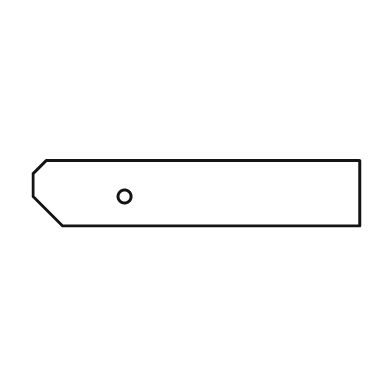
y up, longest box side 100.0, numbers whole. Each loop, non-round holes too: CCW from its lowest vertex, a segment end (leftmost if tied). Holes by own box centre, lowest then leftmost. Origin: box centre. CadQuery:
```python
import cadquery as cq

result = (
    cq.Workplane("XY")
    .moveTo(-41.0, -10.0)
    .lineTo(50.0, -10.0)
    .lineTo(50.0, 10.0)
    .lineTo(-46.0, 10.0)
    .lineTo(-50.0, 6.0)
    .lineTo(-50.0, -1.0)
    .close()
    .moveTo(-22.0, -1.0)
    .circle(2.0)
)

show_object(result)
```